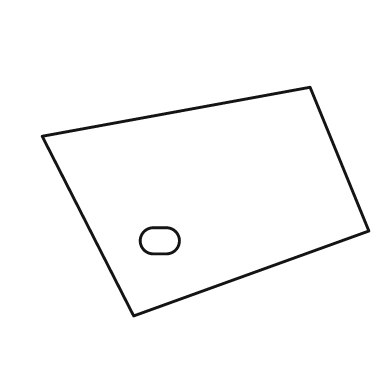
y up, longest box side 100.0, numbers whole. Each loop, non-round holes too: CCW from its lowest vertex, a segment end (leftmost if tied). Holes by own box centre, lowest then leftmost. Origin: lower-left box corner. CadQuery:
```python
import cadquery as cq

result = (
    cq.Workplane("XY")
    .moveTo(28.0, 0.0)
    .lineTo(100.0, 26.0)
    .lineTo(82.0, 70.0)
    .lineTo(0.0, 55.0)
    .close()
    .moveTo(34.0, 19.0)
    .lineTo(38.0, 19.0)
    .threePointArc((42.0, 23.0), (38.0, 27.0))
    .lineTo(34.0, 27.0)
    .threePointArc((30.0, 23.0), (34.0, 19.0))
    .close()
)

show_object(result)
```